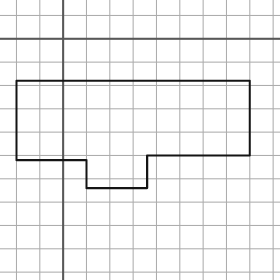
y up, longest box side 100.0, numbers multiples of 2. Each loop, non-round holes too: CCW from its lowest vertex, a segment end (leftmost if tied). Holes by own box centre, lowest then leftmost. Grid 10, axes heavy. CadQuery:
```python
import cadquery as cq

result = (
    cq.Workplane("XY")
    .moveTo(10.0, -64.0)
    .lineTo(36.0, -64.0)
    .lineTo(36.0, -50.0)
    .lineTo(80.0, -50.0)
    .lineTo(80.0, -18.0)
    .lineTo(-20.0, -18.0)
    .lineTo(-20.0, -52.0)
    .lineTo(10.0, -52.0)
    .close()
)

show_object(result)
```